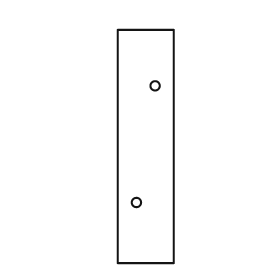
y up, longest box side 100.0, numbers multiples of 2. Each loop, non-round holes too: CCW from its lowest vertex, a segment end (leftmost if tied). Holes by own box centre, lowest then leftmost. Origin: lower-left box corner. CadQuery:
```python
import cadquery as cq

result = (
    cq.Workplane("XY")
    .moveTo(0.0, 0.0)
    .lineTo(24.0, 0.0)
    .lineTo(24.0, 100.0)
    .lineTo(0.0, 100.0)
    .close()
    .moveTo(8.0, 26.0)
    .circle(2.0)
    .moveTo(16.0, 76.0)
    .circle(2.0)
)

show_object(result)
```